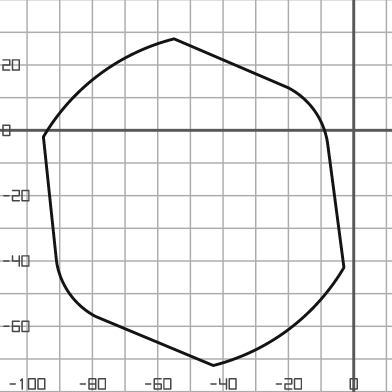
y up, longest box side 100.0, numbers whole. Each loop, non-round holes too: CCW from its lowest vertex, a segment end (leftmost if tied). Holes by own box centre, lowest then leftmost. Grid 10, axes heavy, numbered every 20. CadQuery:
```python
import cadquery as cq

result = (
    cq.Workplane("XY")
    .moveTo(-43.0, -72.0)
    .threePointArc((-20.0, -61.0), (-3.0, -42.0))
    .lineTo(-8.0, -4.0)
    .threePointArc((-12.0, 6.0), (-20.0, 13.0))
    .lineTo(-55.0, 28.0)
    .threePointArc((-78.0, 17.0), (-95.0, -2.0))
    .lineTo(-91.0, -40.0)
    .threePointArc((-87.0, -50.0), (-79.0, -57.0))
    .close()
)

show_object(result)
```